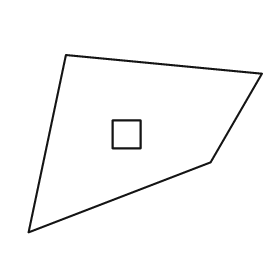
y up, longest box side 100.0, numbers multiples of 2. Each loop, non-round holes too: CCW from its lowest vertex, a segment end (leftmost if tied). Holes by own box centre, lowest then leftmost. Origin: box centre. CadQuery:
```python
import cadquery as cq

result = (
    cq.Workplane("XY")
    .moveTo(-50.0, -38.0)
    .lineTo(28.0, -8.0)
    .lineTo(50.0, 30.0)
    .lineTo(-34.0, 38.0)
    .close()
    .moveTo(-14.0, -2.0)
    .lineTo(-2.0, -2.0)
    .lineTo(-2.0, 10.0)
    .lineTo(-14.0, 10.0)
    .close()
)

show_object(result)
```